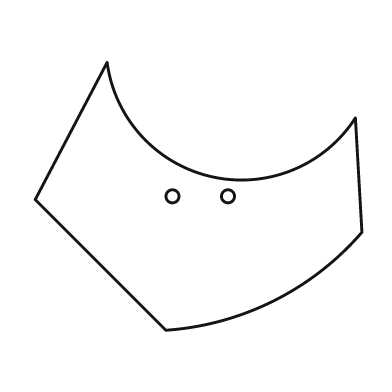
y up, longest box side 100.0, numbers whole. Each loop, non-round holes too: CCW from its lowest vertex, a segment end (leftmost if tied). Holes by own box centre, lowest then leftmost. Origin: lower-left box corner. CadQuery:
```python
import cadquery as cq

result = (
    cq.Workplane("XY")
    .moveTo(40.0, 0.0)
    .threePointArc((73.0, 9.0), (100.0, 30.0))
    .lineTo(98.0, 65.0)
    .threePointArc((54.0, 47.0), (22.0, 82.0))
    .lineTo(0.0, 40.0)
    .close()
    .moveTo(42.0, 41.0)
    .circle(2.0)
    .moveTo(59.0, 41.0)
    .circle(2.0)
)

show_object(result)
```